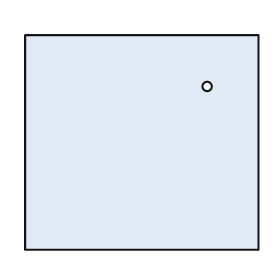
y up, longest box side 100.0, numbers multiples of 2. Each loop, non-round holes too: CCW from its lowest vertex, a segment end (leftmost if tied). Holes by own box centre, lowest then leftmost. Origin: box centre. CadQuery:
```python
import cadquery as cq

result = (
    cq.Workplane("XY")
    .moveTo(-50.0, -46.0)
    .lineTo(50.0, -46.0)
    .lineTo(50.0, 46.0)
    .lineTo(-50.0, 46.0)
    .close()
    .moveTo(28.0, 24.0)
    .circle(2.0)
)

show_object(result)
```